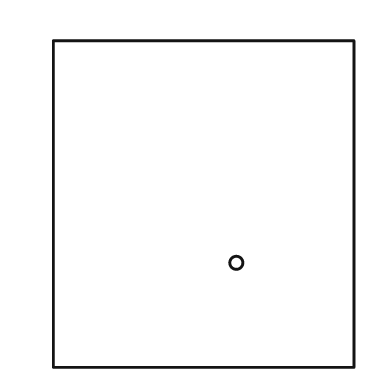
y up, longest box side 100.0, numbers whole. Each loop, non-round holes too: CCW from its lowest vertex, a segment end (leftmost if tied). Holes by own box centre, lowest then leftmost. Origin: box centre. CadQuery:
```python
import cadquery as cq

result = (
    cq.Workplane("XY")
    .moveTo(-46.0, -50.0)
    .lineTo(46.0, -50.0)
    .lineTo(46.0, 50.0)
    .lineTo(-46.0, 50.0)
    .close()
    .moveTo(10.0, -18.0)
    .circle(2.0)
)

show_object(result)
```